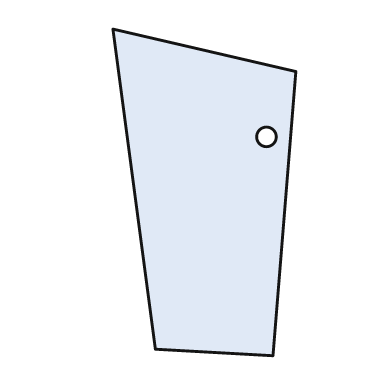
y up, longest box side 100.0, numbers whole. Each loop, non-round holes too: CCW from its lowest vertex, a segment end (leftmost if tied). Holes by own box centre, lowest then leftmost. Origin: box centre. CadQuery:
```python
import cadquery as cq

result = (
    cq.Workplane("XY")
    .moveTo(21.0, -50.0)
    .lineTo(28.0, 37.0)
    .lineTo(-28.0, 50.0)
    .lineTo(-15.0, -48.0)
    .close()
    .moveTo(19.0, 17.0)
    .circle(3.0)
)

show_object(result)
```